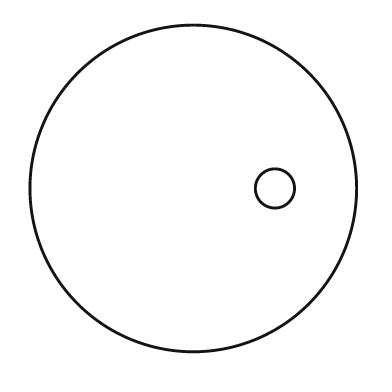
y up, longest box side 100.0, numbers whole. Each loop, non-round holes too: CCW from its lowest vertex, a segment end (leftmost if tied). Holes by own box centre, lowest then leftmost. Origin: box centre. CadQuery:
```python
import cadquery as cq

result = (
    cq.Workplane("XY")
    .moveTo(0.0, 0.0)
    .circle(50.0)
    .moveTo(25.0, 0.0)
    .circle(6.0)
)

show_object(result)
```